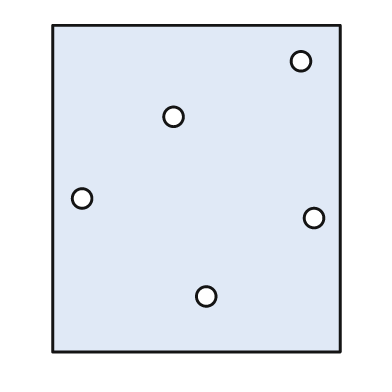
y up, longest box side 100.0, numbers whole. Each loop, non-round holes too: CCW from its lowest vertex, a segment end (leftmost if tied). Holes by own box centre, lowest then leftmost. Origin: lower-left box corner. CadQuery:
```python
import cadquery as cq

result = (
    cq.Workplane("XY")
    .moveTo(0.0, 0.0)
    .lineTo(88.0, 0.0)
    .lineTo(88.0, 100.0)
    .lineTo(0.0, 100.0)
    .close()
    .moveTo(47.0, 17.0)
    .circle(3.0)
    .moveTo(80.0, 41.0)
    .circle(3.0)
    .moveTo(9.0, 47.0)
    .circle(3.0)
    .moveTo(37.0, 72.0)
    .circle(3.0)
    .moveTo(76.0, 89.0)
    .circle(3.0)
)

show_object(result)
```